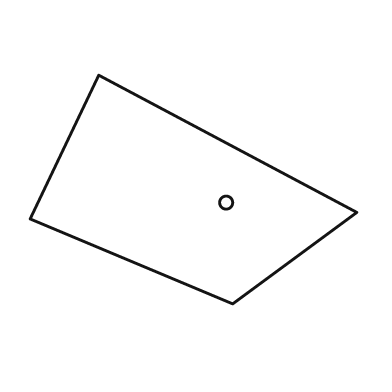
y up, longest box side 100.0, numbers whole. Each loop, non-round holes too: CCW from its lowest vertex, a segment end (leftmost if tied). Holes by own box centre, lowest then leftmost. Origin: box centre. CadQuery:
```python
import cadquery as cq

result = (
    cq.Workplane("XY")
    .moveTo(12.0, -35.0)
    .lineTo(50.0, -7.0)
    .lineTo(-29.0, 35.0)
    .lineTo(-50.0, -9.0)
    .close()
    .moveTo(10.0, -4.0)
    .circle(2.0)
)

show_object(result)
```